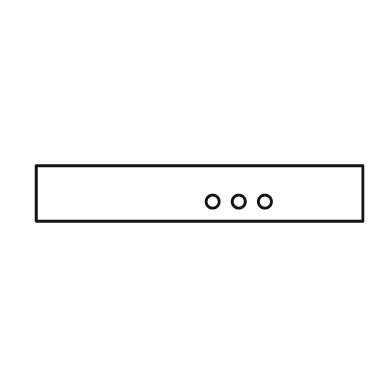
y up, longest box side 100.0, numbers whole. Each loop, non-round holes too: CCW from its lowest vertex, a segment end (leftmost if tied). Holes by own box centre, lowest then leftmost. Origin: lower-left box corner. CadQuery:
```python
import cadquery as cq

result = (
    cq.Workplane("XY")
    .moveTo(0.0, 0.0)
    .lineTo(100.0, 0.0)
    .lineTo(100.0, 17.0)
    .lineTo(0.0, 17.0)
    .close()
    .moveTo(54.0, 6.0)
    .circle(2.0)
    .moveTo(62.0, 6.0)
    .circle(2.0)
    .moveTo(70.0, 6.0)
    .circle(2.0)
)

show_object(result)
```